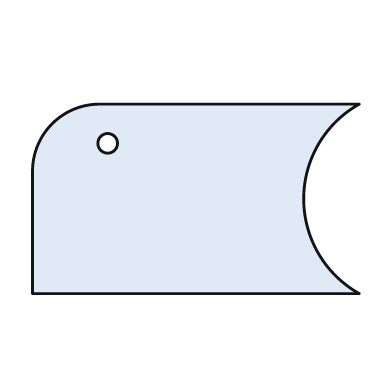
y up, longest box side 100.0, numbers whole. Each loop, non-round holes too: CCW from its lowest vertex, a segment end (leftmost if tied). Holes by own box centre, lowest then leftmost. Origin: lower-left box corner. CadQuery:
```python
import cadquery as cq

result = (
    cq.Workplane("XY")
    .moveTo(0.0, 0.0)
    .lineTo(100.0, 0.0)
    .threePointArc((83.0, 29.0), (100.0, 58.0))
    .lineTo(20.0, 58.0)
    .threePointArc((6.0, 52.0), (0.0, 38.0))
    .close()
    .moveTo(23.0, 46.0)
    .circle(3.0)
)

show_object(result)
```